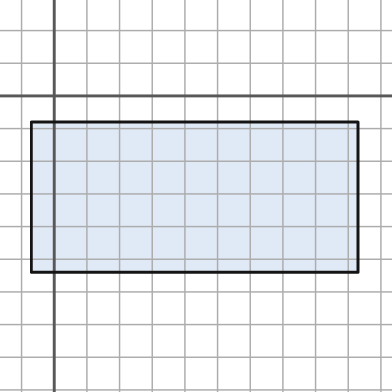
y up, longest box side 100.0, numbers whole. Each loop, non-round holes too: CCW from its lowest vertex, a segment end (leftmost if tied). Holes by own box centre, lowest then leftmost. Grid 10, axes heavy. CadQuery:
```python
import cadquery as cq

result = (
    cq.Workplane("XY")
    .moveTo(-7.0, -54.0)
    .lineTo(93.0, -54.0)
    .lineTo(93.0, -8.0)
    .lineTo(-7.0, -8.0)
    .close()
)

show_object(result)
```